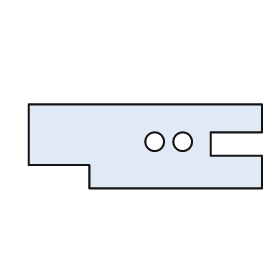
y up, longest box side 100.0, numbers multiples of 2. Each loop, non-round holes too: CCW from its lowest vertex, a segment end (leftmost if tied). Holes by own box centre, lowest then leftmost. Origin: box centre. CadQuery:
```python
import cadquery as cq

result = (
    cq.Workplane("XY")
    .moveTo(-24.0, -18.0)
    .lineTo(50.0, -18.0)
    .lineTo(50.0, -4.0)
    .lineTo(28.0, -4.0)
    .lineTo(28.0, 6.0)
    .lineTo(50.0, 6.0)
    .lineTo(50.0, 18.0)
    .lineTo(-50.0, 18.0)
    .lineTo(-50.0, -8.0)
    .lineTo(-24.0, -8.0)
    .close()
    .moveTo(4.0, 2.0)
    .circle(4.0)
    .moveTo(16.0, 2.0)
    .circle(4.0)
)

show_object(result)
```